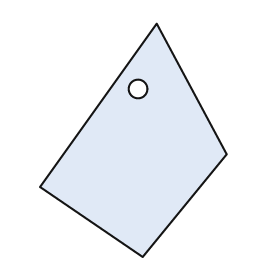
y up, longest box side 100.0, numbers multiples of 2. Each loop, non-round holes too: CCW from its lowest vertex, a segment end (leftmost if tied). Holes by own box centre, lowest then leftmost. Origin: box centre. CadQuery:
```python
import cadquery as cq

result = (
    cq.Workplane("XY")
    .moveTo(4.0, -50.0)
    .lineTo(40.0, -6.0)
    .lineTo(10.0, 50.0)
    .lineTo(-40.0, -20.0)
    .close()
    .moveTo(2.0, 22.0)
    .circle(4.0)
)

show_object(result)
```